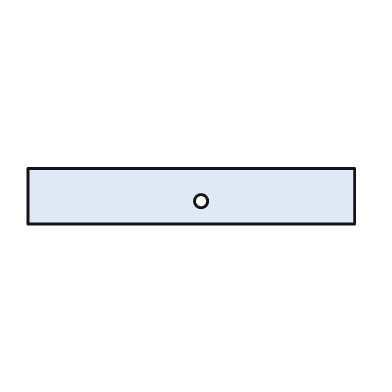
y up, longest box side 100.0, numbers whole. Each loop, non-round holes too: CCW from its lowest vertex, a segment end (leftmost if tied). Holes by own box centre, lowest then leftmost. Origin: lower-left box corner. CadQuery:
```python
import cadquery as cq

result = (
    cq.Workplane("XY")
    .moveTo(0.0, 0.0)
    .lineTo(100.0, 0.0)
    .lineTo(100.0, 17.0)
    .lineTo(0.0, 17.0)
    .close()
    .moveTo(53.0, 7.0)
    .circle(2.0)
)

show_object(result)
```